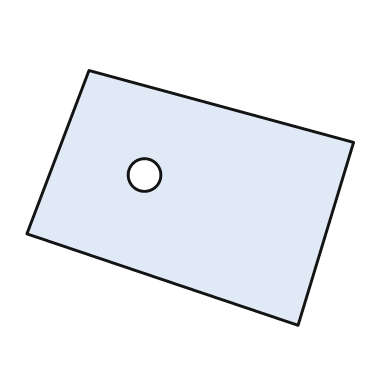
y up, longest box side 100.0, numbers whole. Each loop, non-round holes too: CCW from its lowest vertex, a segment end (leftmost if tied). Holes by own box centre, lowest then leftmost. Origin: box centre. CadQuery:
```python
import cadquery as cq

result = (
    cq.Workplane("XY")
    .moveTo(33.0, -39.0)
    .lineTo(50.0, 17.0)
    .lineTo(-31.0, 39.0)
    .lineTo(-50.0, -11.0)
    .close()
    .moveTo(-14.0, 7.0)
    .circle(5.0)
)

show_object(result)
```